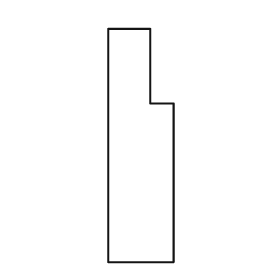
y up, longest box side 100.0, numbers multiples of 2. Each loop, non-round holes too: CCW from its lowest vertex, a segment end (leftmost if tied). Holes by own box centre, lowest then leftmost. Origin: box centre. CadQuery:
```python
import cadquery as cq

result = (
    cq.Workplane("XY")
    .moveTo(-14.0, -50.0)
    .lineTo(14.0, -50.0)
    .lineTo(14.0, 18.0)
    .lineTo(4.0, 18.0)
    .lineTo(4.0, 50.0)
    .lineTo(-14.0, 50.0)
    .close()
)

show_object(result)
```